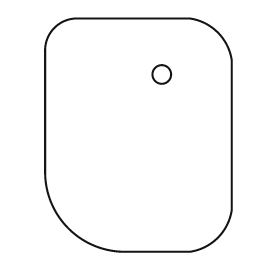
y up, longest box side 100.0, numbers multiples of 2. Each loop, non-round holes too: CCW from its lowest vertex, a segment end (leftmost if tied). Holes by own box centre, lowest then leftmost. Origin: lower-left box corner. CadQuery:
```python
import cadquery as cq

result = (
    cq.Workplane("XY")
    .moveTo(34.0, 0.0)
    .lineTo(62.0, 0.0)
    .threePointArc((74.0, 6.0), (80.0, 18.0))
    .lineTo(80.0, 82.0)
    .threePointArc((74.0, 94.0), (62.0, 100.0))
    .lineTo(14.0, 100.0)
    .threePointArc((4.0, 96.0), (0.0, 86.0))
    .lineTo(0.0, 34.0)
    .threePointArc((10.0, 10.0), (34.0, 0.0))
    .close()
    .moveTo(50.0, 76.0)
    .circle(4.0)
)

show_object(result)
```